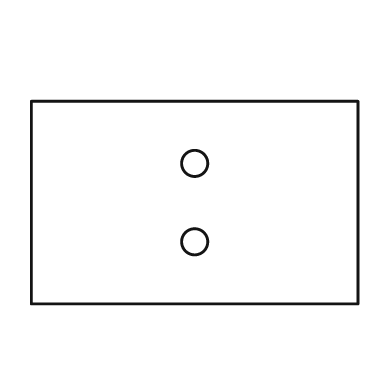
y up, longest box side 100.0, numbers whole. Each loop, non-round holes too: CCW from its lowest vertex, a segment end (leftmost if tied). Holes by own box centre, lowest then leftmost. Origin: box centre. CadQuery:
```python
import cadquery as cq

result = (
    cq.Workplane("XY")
    .moveTo(-50.0, -31.0)
    .lineTo(50.0, -31.0)
    .lineTo(50.0, 31.0)
    .lineTo(-50.0, 31.0)
    .close()
    .moveTo(0.0, -12.0)
    .circle(4.0)
    .moveTo(0.0, 12.0)
    .circle(4.0)
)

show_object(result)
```